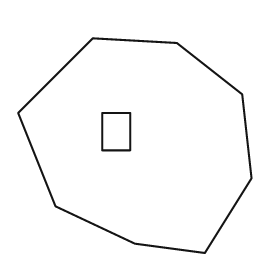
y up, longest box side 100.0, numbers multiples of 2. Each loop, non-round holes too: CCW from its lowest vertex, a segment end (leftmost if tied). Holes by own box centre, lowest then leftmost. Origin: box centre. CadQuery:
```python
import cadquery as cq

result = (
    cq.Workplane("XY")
    .moveTo(30.0, -46.0)
    .lineTo(50.0, -14.0)
    .lineTo(46.0, 22.0)
    .lineTo(18.0, 44.0)
    .lineTo(-18.0, 46.0)
    .lineTo(-50.0, 14.0)
    .lineTo(-34.0, -26.0)
    .lineTo(0.0, -42.0)
    .close()
    .moveTo(-14.0, -2.0)
    .lineTo(-2.0, -2.0)
    .lineTo(-2.0, 14.0)
    .lineTo(-14.0, 14.0)
    .close()
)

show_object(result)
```